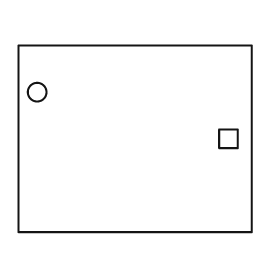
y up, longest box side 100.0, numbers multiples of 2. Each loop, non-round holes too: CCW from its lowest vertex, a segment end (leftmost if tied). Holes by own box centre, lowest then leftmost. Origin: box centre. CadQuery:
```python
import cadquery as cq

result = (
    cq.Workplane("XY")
    .moveTo(-50.0, -40.0)
    .lineTo(50.0, -40.0)
    .lineTo(50.0, 40.0)
    .lineTo(-50.0, 40.0)
    .close()
    .moveTo(36.0, -4.0)
    .lineTo(44.0, -4.0)
    .lineTo(44.0, 4.0)
    .lineTo(36.0, 4.0)
    .close()
    .moveTo(-42.0, 20.0)
    .circle(4.0)
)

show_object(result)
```